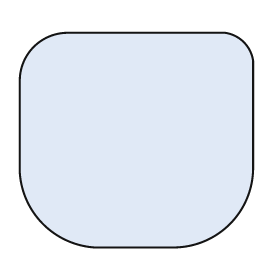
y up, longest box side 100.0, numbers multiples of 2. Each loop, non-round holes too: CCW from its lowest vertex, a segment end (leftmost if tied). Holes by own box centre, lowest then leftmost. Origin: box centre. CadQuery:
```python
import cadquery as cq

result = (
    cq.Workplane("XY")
    .moveTo(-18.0, -46.0)
    .lineTo(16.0, -46.0)
    .threePointArc((40.0, -36.0), (50.0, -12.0))
    .lineTo(50.0, 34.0)
    .threePointArc((46.0, 42.0), (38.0, 46.0))
    .lineTo(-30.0, 46.0)
    .threePointArc((-44.0, 40.0), (-50.0, 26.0))
    .lineTo(-50.0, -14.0)
    .threePointArc((-40.0, -36.0), (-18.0, -46.0))
    .close()
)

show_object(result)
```